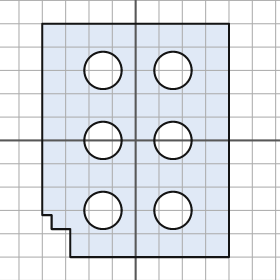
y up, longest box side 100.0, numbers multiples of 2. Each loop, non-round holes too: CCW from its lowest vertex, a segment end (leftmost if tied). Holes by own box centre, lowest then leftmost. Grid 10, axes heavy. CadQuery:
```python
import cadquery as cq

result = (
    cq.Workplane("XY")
    .moveTo(-28.0, -50.0)
    .lineTo(40.0, -50.0)
    .lineTo(40.0, 50.0)
    .lineTo(-40.0, 50.0)
    .lineTo(-40.0, -32.0)
    .lineTo(-36.0, -32.0)
    .lineTo(-36.0, -38.0)
    .lineTo(-28.0, -38.0)
    .close()
    .moveTo(-14.0, -30.0)
    .circle(8.0)
    .moveTo(16.0, -30.0)
    .circle(8.0)
    .moveTo(-14.0, 0.0)
    .circle(8.0)
    .moveTo(16.0, 0.0)
    .circle(8.0)
    .moveTo(-14.0, 30.0)
    .circle(8.0)
    .moveTo(16.0, 30.0)
    .circle(8.0)
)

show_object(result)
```